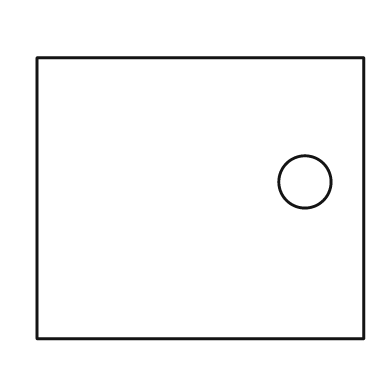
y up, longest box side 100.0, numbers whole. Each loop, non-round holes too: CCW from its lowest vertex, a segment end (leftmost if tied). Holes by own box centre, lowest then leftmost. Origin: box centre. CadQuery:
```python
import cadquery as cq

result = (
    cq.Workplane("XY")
    .moveTo(-50.0, -43.0)
    .lineTo(50.0, -43.0)
    .lineTo(50.0, 43.0)
    .lineTo(-50.0, 43.0)
    .close()
    .moveTo(32.0, 5.0)
    .circle(8.0)
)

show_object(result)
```